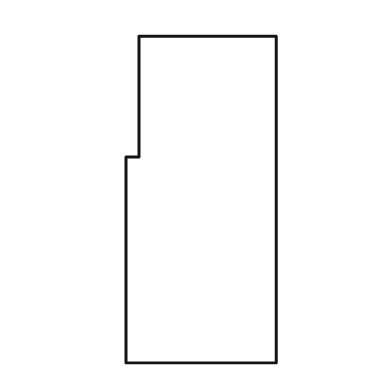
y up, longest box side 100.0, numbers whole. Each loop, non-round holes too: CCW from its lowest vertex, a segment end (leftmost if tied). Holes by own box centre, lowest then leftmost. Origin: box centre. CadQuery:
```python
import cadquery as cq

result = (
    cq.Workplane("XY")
    .moveTo(-23.0, -50.0)
    .lineTo(23.0, -50.0)
    .lineTo(23.0, 50.0)
    .lineTo(-19.0, 50.0)
    .lineTo(-19.0, 13.0)
    .lineTo(-23.0, 13.0)
    .close()
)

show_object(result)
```